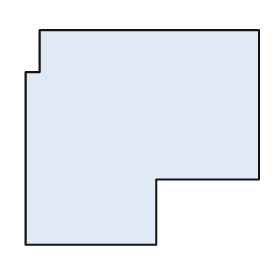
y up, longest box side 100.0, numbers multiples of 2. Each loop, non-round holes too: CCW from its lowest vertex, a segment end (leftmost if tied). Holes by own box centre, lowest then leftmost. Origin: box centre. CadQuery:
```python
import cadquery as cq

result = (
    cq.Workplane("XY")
    .moveTo(-50.0, -46.0)
    .lineTo(6.0, -46.0)
    .lineTo(6.0, -18.0)
    .lineTo(50.0, -18.0)
    .lineTo(50.0, 46.0)
    .lineTo(-44.0, 46.0)
    .lineTo(-44.0, 28.0)
    .lineTo(-50.0, 28.0)
    .close()
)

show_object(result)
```